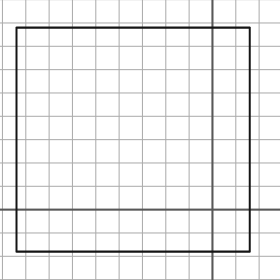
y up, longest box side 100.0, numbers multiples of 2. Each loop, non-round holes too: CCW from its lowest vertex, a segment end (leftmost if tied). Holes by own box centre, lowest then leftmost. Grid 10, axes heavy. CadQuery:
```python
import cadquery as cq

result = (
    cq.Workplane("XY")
    .moveTo(-84.0, -18.0)
    .lineTo(16.0, -18.0)
    .lineTo(16.0, 78.0)
    .lineTo(-84.0, 78.0)
    .close()
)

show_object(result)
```